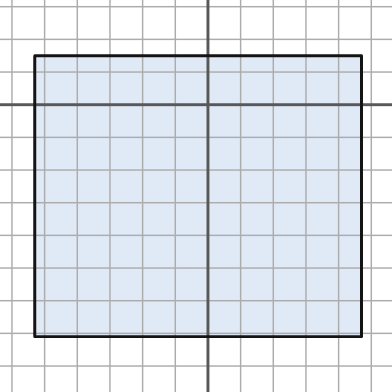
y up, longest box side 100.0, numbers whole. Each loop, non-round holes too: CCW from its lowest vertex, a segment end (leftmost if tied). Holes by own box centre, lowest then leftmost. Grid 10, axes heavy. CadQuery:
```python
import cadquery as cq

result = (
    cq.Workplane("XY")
    .moveTo(-53.0, -71.0)
    .lineTo(47.0, -71.0)
    .lineTo(47.0, 15.0)
    .lineTo(-53.0, 15.0)
    .close()
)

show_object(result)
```